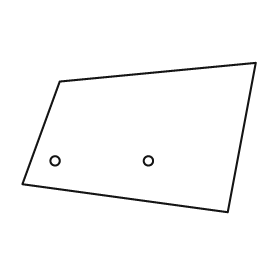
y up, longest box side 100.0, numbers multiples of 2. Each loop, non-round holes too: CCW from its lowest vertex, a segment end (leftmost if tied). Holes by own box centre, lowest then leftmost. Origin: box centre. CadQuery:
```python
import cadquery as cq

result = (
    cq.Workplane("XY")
    .moveTo(38.0, -32.0)
    .lineTo(50.0, 32.0)
    .lineTo(-34.0, 24.0)
    .lineTo(-50.0, -20.0)
    .close()
    .moveTo(-36.0, -10.0)
    .circle(2.0)
    .moveTo(4.0, -10.0)
    .circle(2.0)
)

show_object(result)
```